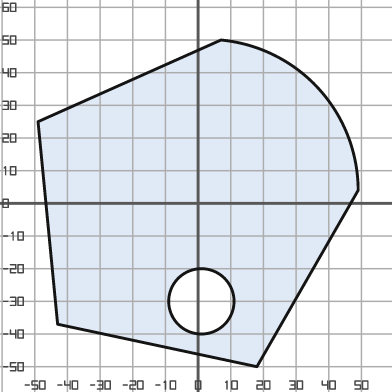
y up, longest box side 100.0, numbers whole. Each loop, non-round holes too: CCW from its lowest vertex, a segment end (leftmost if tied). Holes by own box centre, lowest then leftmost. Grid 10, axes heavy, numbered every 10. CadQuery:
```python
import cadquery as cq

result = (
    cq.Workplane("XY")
    .moveTo(18.0, -50.0)
    .lineTo(49.0, 4.0)
    .threePointArc((37.0, 35.0), (7.0, 50.0))
    .lineTo(-49.0, 25.0)
    .lineTo(-43.0, -37.0)
    .close()
    .moveTo(1.0, -30.0)
    .circle(10.0)
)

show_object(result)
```